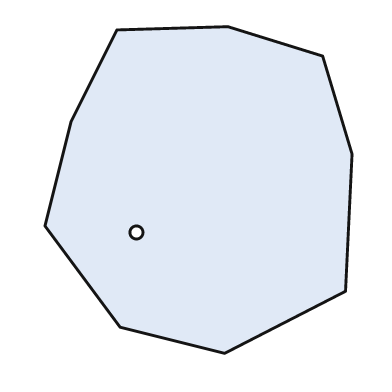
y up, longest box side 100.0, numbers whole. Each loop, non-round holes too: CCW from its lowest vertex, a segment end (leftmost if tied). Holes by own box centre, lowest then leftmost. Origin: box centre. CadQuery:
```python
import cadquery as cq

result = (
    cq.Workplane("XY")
    .moveTo(8.0, -50.0)
    .lineTo(45.0, -31.0)
    .lineTo(47.0, 11.0)
    .lineTo(38.0, 41.0)
    .lineTo(9.0, 50.0)
    .lineTo(-25.0, 49.0)
    .lineTo(-39.0, 21.0)
    .lineTo(-47.0, -11.0)
    .lineTo(-24.0, -42.0)
    .close()
    .moveTo(-19.0, -13.0)
    .circle(2.0)
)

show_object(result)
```